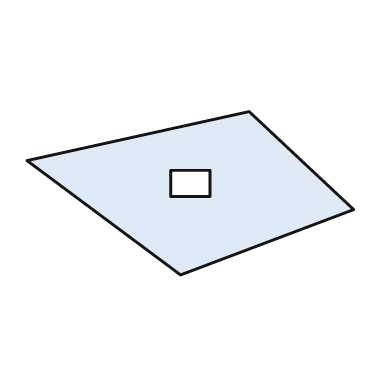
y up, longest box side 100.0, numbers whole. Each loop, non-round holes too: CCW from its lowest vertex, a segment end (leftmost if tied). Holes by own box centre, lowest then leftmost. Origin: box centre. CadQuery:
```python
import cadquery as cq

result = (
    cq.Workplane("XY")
    .moveTo(-3.0, -25.0)
    .lineTo(50.0, -5.0)
    .lineTo(18.0, 25.0)
    .lineTo(-50.0, 10.0)
    .close()
    .moveTo(-6.0, -1.0)
    .lineTo(6.0, -1.0)
    .lineTo(6.0, 7.0)
    .lineTo(-6.0, 7.0)
    .close()
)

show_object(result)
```